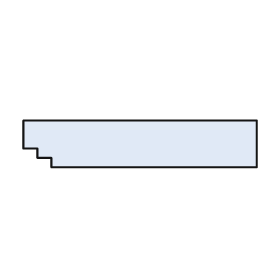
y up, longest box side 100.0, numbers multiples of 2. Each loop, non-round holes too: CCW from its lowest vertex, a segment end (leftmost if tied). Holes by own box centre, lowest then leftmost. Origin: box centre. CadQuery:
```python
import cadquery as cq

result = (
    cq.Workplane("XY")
    .moveTo(-38.0, -10.0)
    .lineTo(50.0, -10.0)
    .lineTo(50.0, 10.0)
    .lineTo(-50.0, 10.0)
    .lineTo(-50.0, -2.0)
    .lineTo(-44.0, -2.0)
    .lineTo(-44.0, -6.0)
    .lineTo(-38.0, -6.0)
    .close()
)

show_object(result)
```